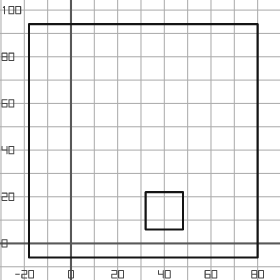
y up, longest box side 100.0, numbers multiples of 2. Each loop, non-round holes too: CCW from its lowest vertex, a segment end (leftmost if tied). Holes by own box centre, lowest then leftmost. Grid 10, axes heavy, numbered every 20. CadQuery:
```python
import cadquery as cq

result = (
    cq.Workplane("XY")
    .moveTo(-18.0, -6.0)
    .lineTo(80.0, -6.0)
    .lineTo(80.0, 94.0)
    .lineTo(-18.0, 94.0)
    .close()
    .moveTo(32.0, 6.0)
    .lineTo(48.0, 6.0)
    .lineTo(48.0, 22.0)
    .lineTo(32.0, 22.0)
    .close()
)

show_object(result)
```